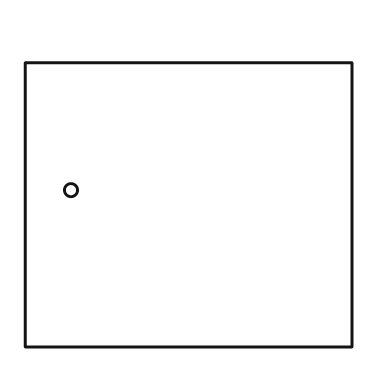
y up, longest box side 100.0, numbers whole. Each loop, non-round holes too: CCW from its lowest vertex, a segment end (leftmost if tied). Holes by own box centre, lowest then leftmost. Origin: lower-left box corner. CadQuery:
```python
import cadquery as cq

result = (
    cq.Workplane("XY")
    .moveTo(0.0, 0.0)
    .lineTo(100.0, 0.0)
    .lineTo(100.0, 87.0)
    .lineTo(0.0, 87.0)
    .close()
    .moveTo(14.0, 48.0)
    .circle(2.0)
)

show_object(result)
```